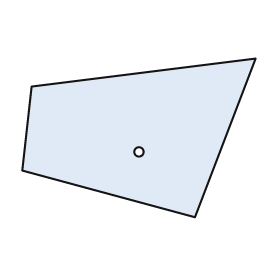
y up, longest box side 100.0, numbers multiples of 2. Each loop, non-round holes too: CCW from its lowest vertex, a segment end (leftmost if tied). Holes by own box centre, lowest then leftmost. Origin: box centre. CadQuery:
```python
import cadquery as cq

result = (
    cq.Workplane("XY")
    .moveTo(24.0, -34.0)
    .lineTo(50.0, 34.0)
    .lineTo(-46.0, 22.0)
    .lineTo(-50.0, -14.0)
    .close()
    .moveTo(0.0, -6.0)
    .circle(2.0)
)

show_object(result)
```